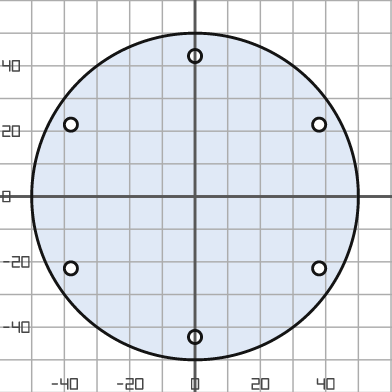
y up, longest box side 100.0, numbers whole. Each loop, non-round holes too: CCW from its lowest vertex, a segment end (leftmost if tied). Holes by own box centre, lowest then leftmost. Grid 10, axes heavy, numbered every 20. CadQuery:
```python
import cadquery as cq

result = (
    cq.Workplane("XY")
    .moveTo(0.0, 0.0)
    .circle(50.0)
    .moveTo(0.0, -43.0)
    .circle(2.0)
    .moveTo(-38.0, -22.0)
    .circle(2.0)
    .moveTo(38.0, -22.0)
    .circle(2.0)
    .moveTo(-38.0, 22.0)
    .circle(2.0)
    .moveTo(38.0, 22.0)
    .circle(2.0)
    .moveTo(0.0, 43.0)
    .circle(2.0)
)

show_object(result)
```